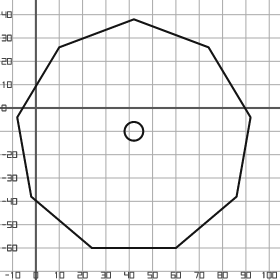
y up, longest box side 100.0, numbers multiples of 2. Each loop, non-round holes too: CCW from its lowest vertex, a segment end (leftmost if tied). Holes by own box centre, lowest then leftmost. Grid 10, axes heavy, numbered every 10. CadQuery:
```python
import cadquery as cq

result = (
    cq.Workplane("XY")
    .moveTo(24.0, -60.0)
    .lineTo(60.0, -60.0)
    .lineTo(86.0, -38.0)
    .lineTo(92.0, -4.0)
    .lineTo(74.0, 26.0)
    .lineTo(42.0, 38.0)
    .lineTo(10.0, 26.0)
    .lineTo(-8.0, -4.0)
    .lineTo(-2.0, -38.0)
    .close()
    .moveTo(42.0, -10.0)
    .circle(4.0)
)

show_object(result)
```